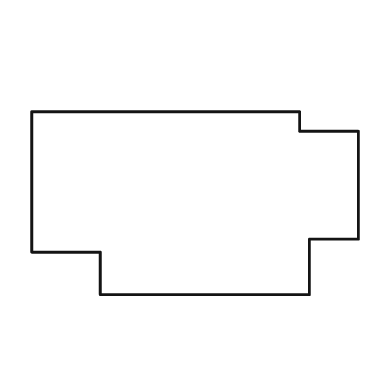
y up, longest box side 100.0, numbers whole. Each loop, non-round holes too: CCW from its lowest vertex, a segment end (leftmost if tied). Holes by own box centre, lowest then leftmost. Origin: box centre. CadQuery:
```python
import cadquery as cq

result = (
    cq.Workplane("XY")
    .moveTo(-29.0, -28.0)
    .lineTo(35.0, -28.0)
    .lineTo(35.0, -11.0)
    .lineTo(50.0, -11.0)
    .lineTo(50.0, 22.0)
    .lineTo(32.0, 22.0)
    .lineTo(32.0, 28.0)
    .lineTo(-50.0, 28.0)
    .lineTo(-50.0, -15.0)
    .lineTo(-29.0, -15.0)
    .close()
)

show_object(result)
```